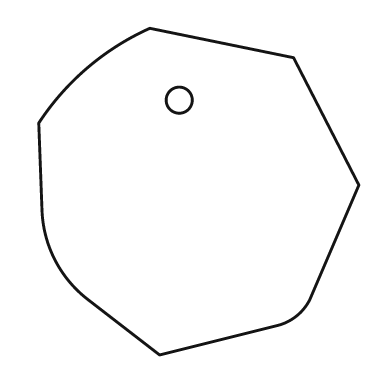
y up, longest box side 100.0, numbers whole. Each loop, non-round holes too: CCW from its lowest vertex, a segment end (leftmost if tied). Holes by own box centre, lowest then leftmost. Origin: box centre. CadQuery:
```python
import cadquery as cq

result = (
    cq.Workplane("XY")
    .moveTo(-12.0, -50.0)
    .lineTo(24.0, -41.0)
    .threePointArc((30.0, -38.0), (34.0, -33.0))
    .lineTo(49.0, 2.0)
    .lineTo(29.0, 41.0)
    .lineTo(-15.0, 50.0)
    .threePointArc((-34.0, 38.0), (-49.0, 21.0))
    .lineTo(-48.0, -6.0)
    .threePointArc((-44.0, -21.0), (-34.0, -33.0))
    .close()
    .moveTo(-6.0, 28.0)
    .circle(4.0)
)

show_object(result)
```